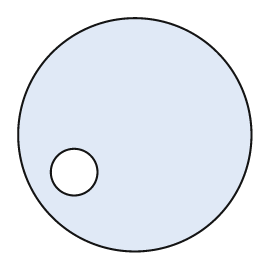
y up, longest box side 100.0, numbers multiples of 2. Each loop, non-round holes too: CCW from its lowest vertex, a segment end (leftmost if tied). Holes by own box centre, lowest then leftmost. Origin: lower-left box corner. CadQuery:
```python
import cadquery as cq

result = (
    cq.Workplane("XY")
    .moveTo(50.0, 50.0)
    .circle(50.0)
    .moveTo(24.0, 34.0)
    .circle(10.0)
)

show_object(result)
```